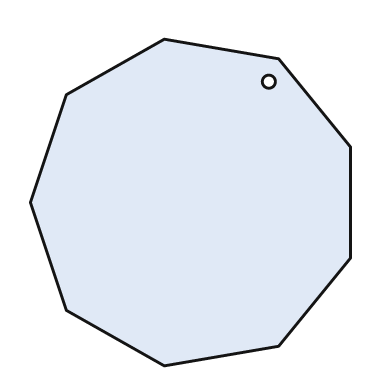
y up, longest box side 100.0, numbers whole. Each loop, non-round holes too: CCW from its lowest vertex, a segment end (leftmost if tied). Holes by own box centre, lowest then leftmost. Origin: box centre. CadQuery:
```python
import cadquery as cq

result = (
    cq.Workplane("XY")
    .moveTo(-8.0, -50.0)
    .lineTo(27.0, -44.0)
    .lineTo(49.0, -17.0)
    .lineTo(49.0, 17.0)
    .lineTo(27.0, 44.0)
    .lineTo(-8.0, 50.0)
    .lineTo(-38.0, 33.0)
    .lineTo(-49.0, 0.0)
    .lineTo(-38.0, -33.0)
    .close()
    .moveTo(24.0, 37.0)
    .circle(2.0)
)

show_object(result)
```